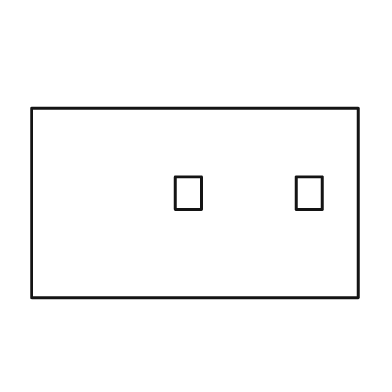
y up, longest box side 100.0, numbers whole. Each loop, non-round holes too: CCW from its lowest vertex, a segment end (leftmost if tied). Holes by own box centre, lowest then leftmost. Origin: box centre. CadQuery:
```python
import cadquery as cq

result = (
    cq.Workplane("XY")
    .moveTo(-50.0, -29.0)
    .lineTo(50.0, -29.0)
    .lineTo(50.0, 29.0)
    .lineTo(-50.0, 29.0)
    .close()
    .moveTo(-6.0, -2.0)
    .lineTo(2.0, -2.0)
    .lineTo(2.0, 8.0)
    .lineTo(-6.0, 8.0)
    .close()
    .moveTo(31.0, -2.0)
    .lineTo(39.0, -2.0)
    .lineTo(39.0, 8.0)
    .lineTo(31.0, 8.0)
    .close()
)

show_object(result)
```